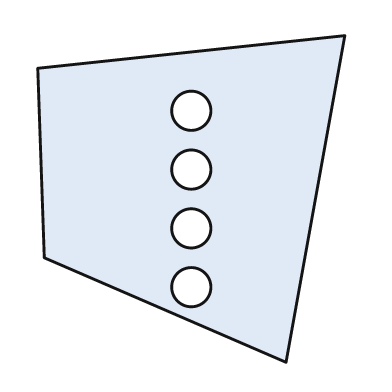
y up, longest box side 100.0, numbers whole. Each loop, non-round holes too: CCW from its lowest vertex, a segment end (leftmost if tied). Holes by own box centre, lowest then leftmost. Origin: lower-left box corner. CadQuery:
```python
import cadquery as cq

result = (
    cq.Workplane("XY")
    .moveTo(76.0, 0.0)
    .lineTo(94.0, 100.0)
    .lineTo(0.0, 90.0)
    .lineTo(2.0, 32.0)
    .close()
    .moveTo(47.0, 23.0)
    .circle(6.0)
    .moveTo(47.0, 41.0)
    .circle(6.0)
    .moveTo(47.0, 59.0)
    .circle(6.0)
    .moveTo(47.0, 77.0)
    .circle(6.0)
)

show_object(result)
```